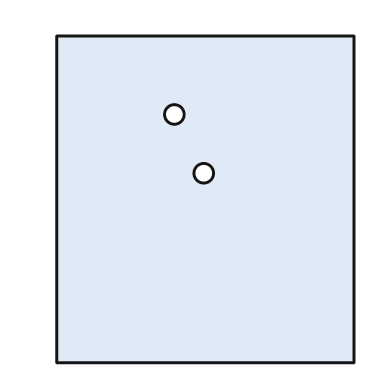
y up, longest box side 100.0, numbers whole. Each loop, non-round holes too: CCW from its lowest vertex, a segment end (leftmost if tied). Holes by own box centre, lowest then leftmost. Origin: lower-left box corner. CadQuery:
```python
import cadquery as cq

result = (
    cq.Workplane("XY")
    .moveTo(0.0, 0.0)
    .lineTo(91.0, 0.0)
    .lineTo(91.0, 100.0)
    .lineTo(0.0, 100.0)
    .close()
    .moveTo(45.0, 58.0)
    .circle(3.0)
    .moveTo(36.0, 76.0)
    .circle(3.0)
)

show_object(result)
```